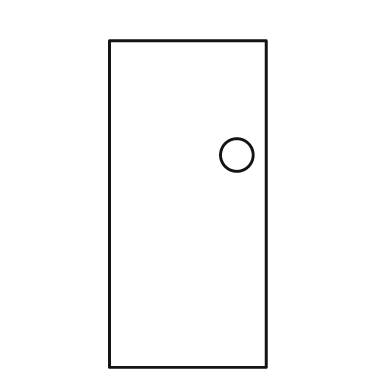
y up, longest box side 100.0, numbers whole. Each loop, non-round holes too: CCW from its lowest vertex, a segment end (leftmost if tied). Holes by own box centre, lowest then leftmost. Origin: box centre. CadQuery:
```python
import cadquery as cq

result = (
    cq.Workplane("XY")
    .moveTo(-24.0, -50.0)
    .lineTo(24.0, -50.0)
    .lineTo(24.0, 50.0)
    .lineTo(-24.0, 50.0)
    .close()
    .moveTo(15.0, 15.0)
    .circle(5.0)
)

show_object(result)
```